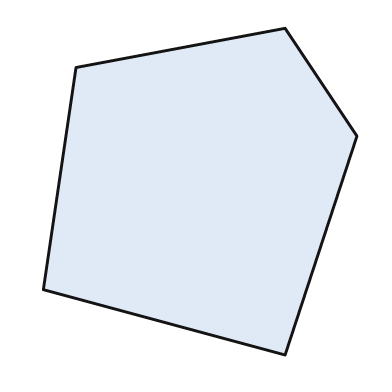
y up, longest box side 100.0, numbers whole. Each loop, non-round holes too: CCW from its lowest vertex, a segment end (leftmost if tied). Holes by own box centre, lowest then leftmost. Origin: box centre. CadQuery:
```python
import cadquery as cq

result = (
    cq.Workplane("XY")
    .moveTo(26.0, -50.0)
    .lineTo(48.0, 17.0)
    .lineTo(26.0, 50.0)
    .lineTo(-38.0, 38.0)
    .lineTo(-48.0, -30.0)
    .close()
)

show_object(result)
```